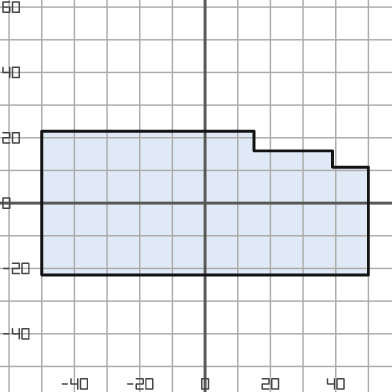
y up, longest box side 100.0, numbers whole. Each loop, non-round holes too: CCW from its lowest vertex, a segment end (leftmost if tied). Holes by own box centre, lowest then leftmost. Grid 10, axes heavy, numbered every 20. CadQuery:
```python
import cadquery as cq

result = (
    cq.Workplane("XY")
    .moveTo(-50.0, -22.0)
    .lineTo(50.0, -22.0)
    .lineTo(50.0, 11.0)
    .lineTo(39.0, 11.0)
    .lineTo(39.0, 16.0)
    .lineTo(15.0, 16.0)
    .lineTo(15.0, 22.0)
    .lineTo(-50.0, 22.0)
    .close()
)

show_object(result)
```